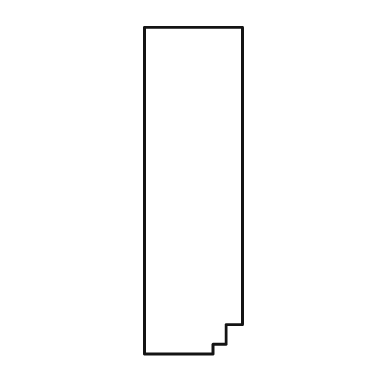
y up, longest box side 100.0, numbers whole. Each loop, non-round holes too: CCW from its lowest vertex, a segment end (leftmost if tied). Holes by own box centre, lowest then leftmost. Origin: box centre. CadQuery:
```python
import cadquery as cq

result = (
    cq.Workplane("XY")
    .moveTo(-15.0, -50.0)
    .lineTo(6.0, -50.0)
    .lineTo(6.0, -47.0)
    .lineTo(10.0, -47.0)
    .lineTo(10.0, -41.0)
    .lineTo(15.0, -41.0)
    .lineTo(15.0, 50.0)
    .lineTo(-15.0, 50.0)
    .close()
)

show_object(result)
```